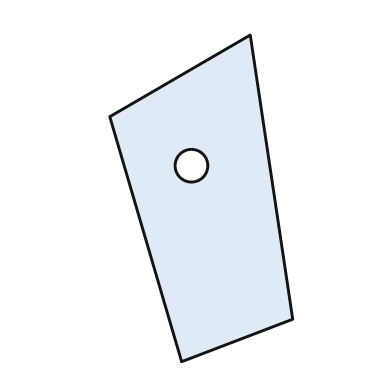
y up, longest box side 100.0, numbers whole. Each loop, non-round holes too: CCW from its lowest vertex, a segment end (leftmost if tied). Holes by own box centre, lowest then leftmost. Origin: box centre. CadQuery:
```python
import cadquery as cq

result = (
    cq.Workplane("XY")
    .moveTo(-6.0, -50.0)
    .lineTo(28.0, -37.0)
    .lineTo(15.0, 50.0)
    .lineTo(-28.0, 25.0)
    .close()
    .moveTo(-3.0, 10.0)
    .circle(5.0)
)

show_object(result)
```